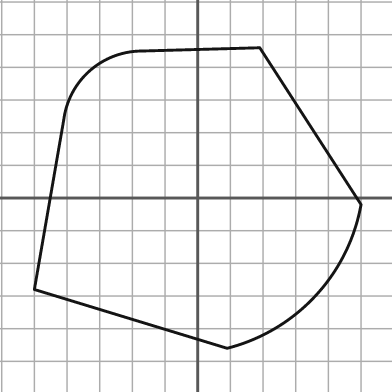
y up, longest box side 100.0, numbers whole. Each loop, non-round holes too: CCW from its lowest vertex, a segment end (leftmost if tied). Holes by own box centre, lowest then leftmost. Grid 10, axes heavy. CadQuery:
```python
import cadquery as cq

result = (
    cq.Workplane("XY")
    .moveTo(9.0, -46.0)
    .threePointArc((36.0, -30.0), (50.0, -2.0))
    .lineTo(19.0, 46.0)
    .lineTo(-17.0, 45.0)
    .threePointArc((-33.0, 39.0), (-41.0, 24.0))
    .lineTo(-50.0, -28.0)
    .close()
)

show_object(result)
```